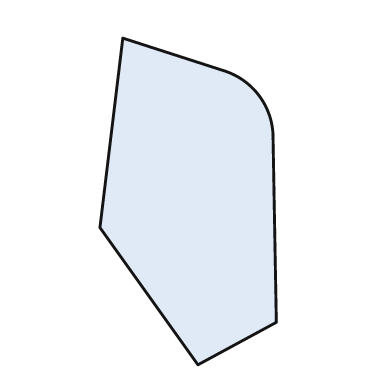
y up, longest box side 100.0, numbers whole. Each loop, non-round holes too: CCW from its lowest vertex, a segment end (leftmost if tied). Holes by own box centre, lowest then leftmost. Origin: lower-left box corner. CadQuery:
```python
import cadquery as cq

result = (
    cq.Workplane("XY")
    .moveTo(30.0, 0.0)
    .lineTo(54.0, 13.0)
    .lineTo(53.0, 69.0)
    .threePointArc((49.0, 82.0), (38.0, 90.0))
    .lineTo(7.0, 100.0)
    .lineTo(0.0, 42.0)
    .close()
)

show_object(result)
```